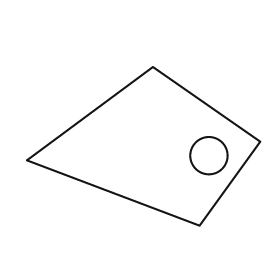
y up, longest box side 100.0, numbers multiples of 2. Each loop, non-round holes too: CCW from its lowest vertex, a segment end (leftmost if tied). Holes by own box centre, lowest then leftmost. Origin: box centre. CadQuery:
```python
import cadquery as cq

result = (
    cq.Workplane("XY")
    .moveTo(24.0, -34.0)
    .lineTo(50.0, 2.0)
    .lineTo(4.0, 34.0)
    .lineTo(-50.0, -6.0)
    .close()
    .moveTo(28.0, -4.0)
    .circle(8.0)
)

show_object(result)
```